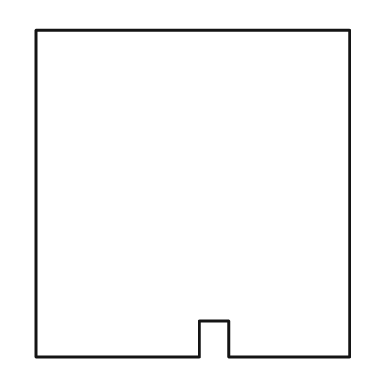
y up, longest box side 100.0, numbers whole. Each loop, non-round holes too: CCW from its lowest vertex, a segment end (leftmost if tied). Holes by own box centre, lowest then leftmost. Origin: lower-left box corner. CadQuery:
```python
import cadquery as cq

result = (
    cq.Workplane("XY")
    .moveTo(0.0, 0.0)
    .lineTo(50.0, 0.0)
    .lineTo(50.0, 11.0)
    .lineTo(59.0, 11.0)
    .lineTo(59.0, 0.0)
    .lineTo(96.0, 0.0)
    .lineTo(96.0, 100.0)
    .lineTo(0.0, 100.0)
    .close()
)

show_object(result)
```